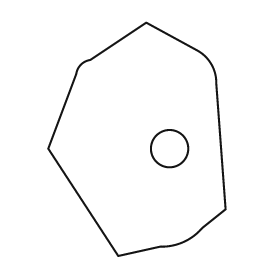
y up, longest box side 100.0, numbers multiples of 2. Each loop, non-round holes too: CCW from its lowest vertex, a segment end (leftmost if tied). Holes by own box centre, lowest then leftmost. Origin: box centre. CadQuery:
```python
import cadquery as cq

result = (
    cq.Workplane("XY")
    .moveTo(-8.0, -50.0)
    .lineTo(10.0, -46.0)
    .threePointArc((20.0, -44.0), (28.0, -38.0))
    .lineTo(38.0, -30.0)
    .lineTo(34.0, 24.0)
    .threePointArc((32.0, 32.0), (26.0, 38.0))
    .lineTo(4.0, 50.0)
    .lineTo(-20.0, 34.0)
    .threePointArc((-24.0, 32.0), (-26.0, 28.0))
    .lineTo(-38.0, -4.0)
    .close()
    .moveTo(14.0, -4.0)
    .circle(8.0)
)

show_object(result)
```